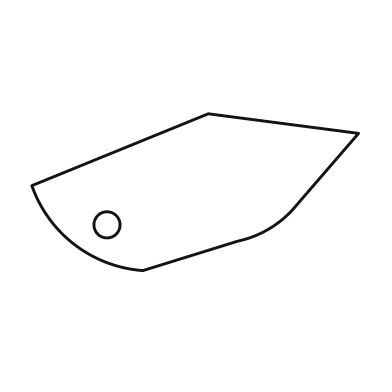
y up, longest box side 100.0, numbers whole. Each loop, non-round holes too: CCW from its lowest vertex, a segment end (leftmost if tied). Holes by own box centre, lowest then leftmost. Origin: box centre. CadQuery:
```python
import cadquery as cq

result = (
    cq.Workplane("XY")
    .moveTo(-16.0, -24.0)
    .lineTo(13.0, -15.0)
    .threePointArc((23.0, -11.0), (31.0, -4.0))
    .lineTo(50.0, 18.0)
    .lineTo(4.0, 24.0)
    .lineTo(-50.0, 2.0)
    .threePointArc((-37.0, -16.0), (-16.0, -24.0))
    .close()
    .moveTo(-27.0, -10.0)
    .circle(4.0)
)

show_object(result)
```